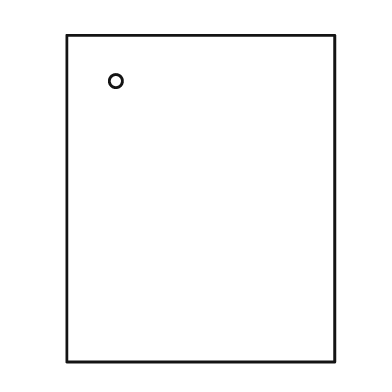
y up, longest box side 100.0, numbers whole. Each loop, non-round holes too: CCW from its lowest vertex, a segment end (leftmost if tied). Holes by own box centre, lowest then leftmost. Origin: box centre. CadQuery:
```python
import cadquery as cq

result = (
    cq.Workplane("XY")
    .moveTo(-41.0, -50.0)
    .lineTo(41.0, -50.0)
    .lineTo(41.0, 50.0)
    .lineTo(-41.0, 50.0)
    .close()
    .moveTo(-26.0, 36.0)
    .circle(2.0)
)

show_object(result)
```